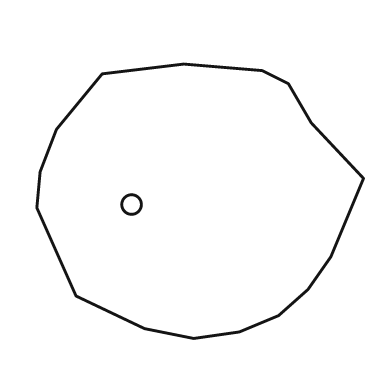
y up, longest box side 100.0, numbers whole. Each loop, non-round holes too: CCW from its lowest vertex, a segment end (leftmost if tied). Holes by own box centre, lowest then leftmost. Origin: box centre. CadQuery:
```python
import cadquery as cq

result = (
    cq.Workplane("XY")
    .moveTo(-2.0, -42.0)
    .lineTo(12.0, -40.0)
    .lineTo(24.0, -35.0)
    .lineTo(33.0, -27.0)
    .lineTo(40.0, -17.0)
    .lineTo(50.0, 7.0)
    .lineTo(34.0, 24.0)
    .lineTo(27.0, 36.0)
    .lineTo(19.0, 40.0)
    .lineTo(-5.0, 42.0)
    .lineTo(-30.0, 39.0)
    .lineTo(-44.0, 22.0)
    .lineTo(-49.0, 9.0)
    .lineTo(-50.0, -2.0)
    .lineTo(-38.0, -29.0)
    .lineTo(-17.0, -39.0)
    .close()
    .moveTo(-21.0, -1.0)
    .circle(3.0)
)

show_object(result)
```